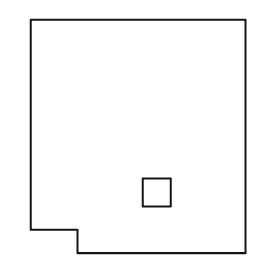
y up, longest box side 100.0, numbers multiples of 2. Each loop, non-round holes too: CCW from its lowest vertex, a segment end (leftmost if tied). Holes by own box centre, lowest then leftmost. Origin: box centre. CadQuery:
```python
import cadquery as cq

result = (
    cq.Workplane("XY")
    .moveTo(-26.0, -50.0)
    .lineTo(46.0, -50.0)
    .lineTo(46.0, 50.0)
    .lineTo(-46.0, 50.0)
    .lineTo(-46.0, -40.0)
    .lineTo(-26.0, -40.0)
    .close()
    .moveTo(2.0, -30.0)
    .lineTo(14.0, -30.0)
    .lineTo(14.0, -18.0)
    .lineTo(2.0, -18.0)
    .close()
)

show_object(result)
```